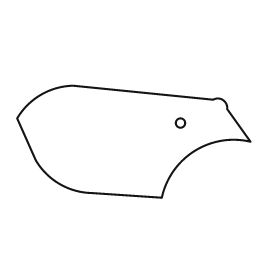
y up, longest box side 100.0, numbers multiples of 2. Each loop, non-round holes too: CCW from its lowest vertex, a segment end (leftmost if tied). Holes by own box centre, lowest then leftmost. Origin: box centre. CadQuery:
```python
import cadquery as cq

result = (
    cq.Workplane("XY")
    .moveTo(12.0, -24.0)
    .threePointArc((26.0, -4.0), (50.0, 0.0))
    .lineTo(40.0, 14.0)
    .threePointArc((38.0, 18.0), (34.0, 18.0))
    .lineTo(-26.0, 24.0)
    .threePointArc((-40.0, 20.0), (-50.0, 10.0))
    .lineTo(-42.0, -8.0)
    .threePointArc((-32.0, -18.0), (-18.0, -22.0))
    .close()
    .moveTo(20.0, 8.0)
    .circle(2.0)
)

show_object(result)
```